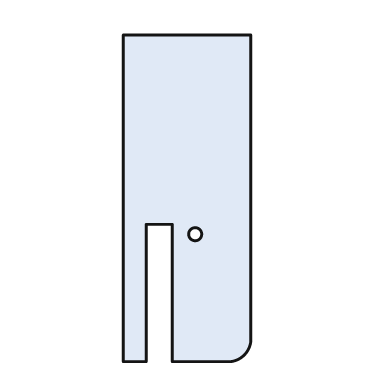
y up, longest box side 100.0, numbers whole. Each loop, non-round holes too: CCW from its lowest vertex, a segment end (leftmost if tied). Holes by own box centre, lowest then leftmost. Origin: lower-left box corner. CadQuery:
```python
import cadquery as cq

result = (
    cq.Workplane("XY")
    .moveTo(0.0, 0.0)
    .lineTo(7.0, 0.0)
    .lineTo(7.0, 42.0)
    .lineTo(15.0, 42.0)
    .lineTo(15.0, 0.0)
    .lineTo(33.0, 0.0)
    .threePointArc((37.0, 2.0), (39.0, 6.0))
    .lineTo(39.0, 100.0)
    .lineTo(0.0, 100.0)
    .close()
    .moveTo(22.0, 39.0)
    .circle(2.0)
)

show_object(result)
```